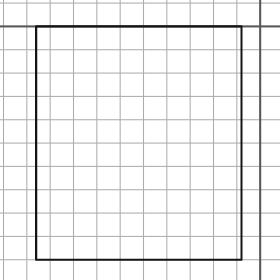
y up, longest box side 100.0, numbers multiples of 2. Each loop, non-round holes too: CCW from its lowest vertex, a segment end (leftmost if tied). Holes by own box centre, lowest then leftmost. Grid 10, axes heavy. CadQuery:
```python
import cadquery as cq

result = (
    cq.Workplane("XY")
    .moveTo(-96.0, -100.0)
    .lineTo(-8.0, -100.0)
    .lineTo(-8.0, 0.0)
    .lineTo(-96.0, 0.0)
    .close()
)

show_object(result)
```